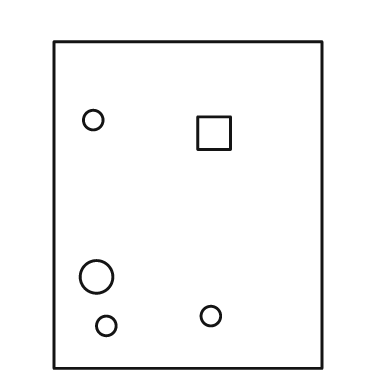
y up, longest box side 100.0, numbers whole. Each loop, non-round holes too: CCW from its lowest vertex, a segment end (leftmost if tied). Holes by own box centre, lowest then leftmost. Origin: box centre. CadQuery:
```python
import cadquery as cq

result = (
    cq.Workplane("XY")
    .moveTo(-41.0, -50.0)
    .lineTo(41.0, -50.0)
    .lineTo(41.0, 50.0)
    .lineTo(-41.0, 50.0)
    .close()
    .moveTo(-25.0, -37.0)
    .circle(3.0)
    .moveTo(7.0, -34.0)
    .circle(3.0)
    .moveTo(-28.0, -22.0)
    .circle(5.0)
    .moveTo(3.0, 17.0)
    .lineTo(13.0, 17.0)
    .lineTo(13.0, 27.0)
    .lineTo(3.0, 27.0)
    .close()
    .moveTo(-29.0, 26.0)
    .circle(3.0)
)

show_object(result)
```